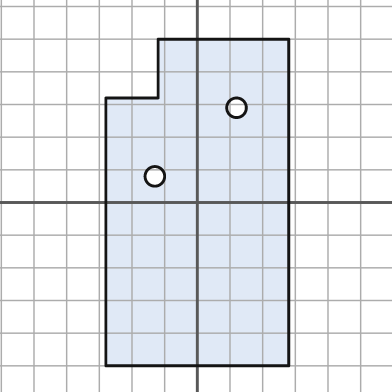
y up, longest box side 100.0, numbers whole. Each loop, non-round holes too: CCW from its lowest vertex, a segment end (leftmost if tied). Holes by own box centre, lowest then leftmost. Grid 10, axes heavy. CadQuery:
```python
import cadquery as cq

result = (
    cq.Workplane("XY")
    .moveTo(-28.0, -50.0)
    .lineTo(28.0, -50.0)
    .lineTo(28.0, 50.0)
    .lineTo(-12.0, 50.0)
    .lineTo(-12.0, 32.0)
    .lineTo(-28.0, 32.0)
    .close()
    .moveTo(-13.0, 8.0)
    .circle(3.0)
    .moveTo(12.0, 29.0)
    .circle(3.0)
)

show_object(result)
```